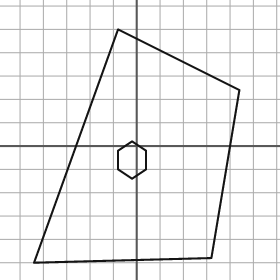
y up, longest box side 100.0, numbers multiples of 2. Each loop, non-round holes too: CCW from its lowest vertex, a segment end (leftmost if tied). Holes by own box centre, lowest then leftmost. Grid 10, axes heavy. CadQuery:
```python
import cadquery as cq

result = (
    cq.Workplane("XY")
    .moveTo(-44.0, -50.0)
    .lineTo(32.0, -48.0)
    .lineTo(44.0, 24.0)
    .lineTo(-8.0, 50.0)
    .close()
    .moveTo(-2.0, -14.0)
    .lineTo(4.0, -10.0)
    .lineTo(4.0, -2.0)
    .lineTo(-2.0, 2.0)
    .lineTo(-8.0, -2.0)
    .lineTo(-8.0, -10.0)
    .close()
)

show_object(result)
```